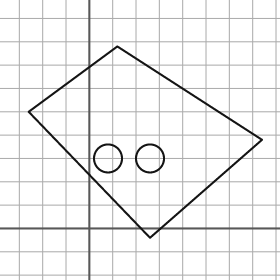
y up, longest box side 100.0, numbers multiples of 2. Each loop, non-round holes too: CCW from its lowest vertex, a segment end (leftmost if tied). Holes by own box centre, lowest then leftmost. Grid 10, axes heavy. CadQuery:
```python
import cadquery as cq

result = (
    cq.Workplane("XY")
    .moveTo(26.0, -4.0)
    .lineTo(74.0, 38.0)
    .lineTo(12.0, 78.0)
    .lineTo(-26.0, 50.0)
    .close()
    .moveTo(8.0, 30.0)
    .circle(6.0)
    .moveTo(26.0, 30.0)
    .circle(6.0)
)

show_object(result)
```